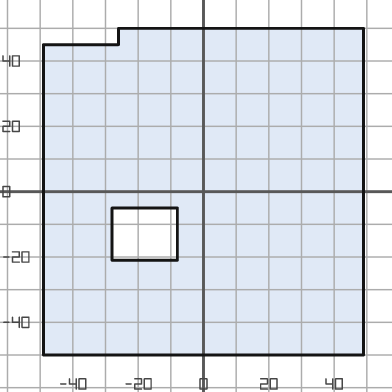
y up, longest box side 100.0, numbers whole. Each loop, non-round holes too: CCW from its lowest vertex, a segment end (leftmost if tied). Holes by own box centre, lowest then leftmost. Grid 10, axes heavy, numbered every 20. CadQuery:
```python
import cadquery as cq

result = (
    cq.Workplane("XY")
    .moveTo(-49.0, -50.0)
    .lineTo(49.0, -50.0)
    .lineTo(49.0, 50.0)
    .lineTo(-26.0, 50.0)
    .lineTo(-26.0, 45.0)
    .lineTo(-49.0, 45.0)
    .close()
    .moveTo(-28.0, -21.0)
    .lineTo(-8.0, -21.0)
    .lineTo(-8.0, -5.0)
    .lineTo(-28.0, -5.0)
    .close()
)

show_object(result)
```